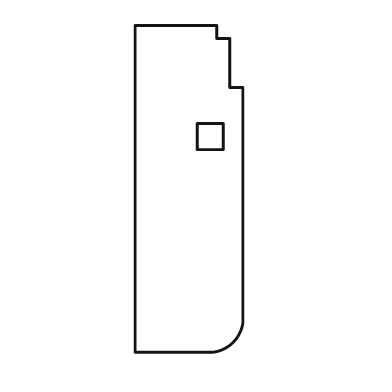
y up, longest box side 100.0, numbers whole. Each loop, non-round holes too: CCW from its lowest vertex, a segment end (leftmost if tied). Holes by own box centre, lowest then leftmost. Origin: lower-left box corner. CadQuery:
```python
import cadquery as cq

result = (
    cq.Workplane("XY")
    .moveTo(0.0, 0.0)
    .lineTo(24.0, 0.0)
    .threePointArc((30.0, 3.0), (33.0, 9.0))
    .lineTo(33.0, 81.0)
    .lineTo(29.0, 81.0)
    .lineTo(29.0, 96.0)
    .lineTo(25.0, 96.0)
    .lineTo(25.0, 100.0)
    .lineTo(0.0, 100.0)
    .close()
    .moveTo(19.0, 62.0)
    .lineTo(27.0, 62.0)
    .lineTo(27.0, 70.0)
    .lineTo(19.0, 70.0)
    .close()
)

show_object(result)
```